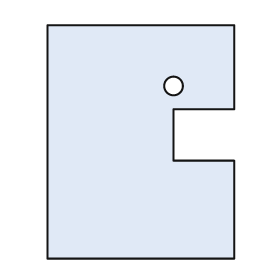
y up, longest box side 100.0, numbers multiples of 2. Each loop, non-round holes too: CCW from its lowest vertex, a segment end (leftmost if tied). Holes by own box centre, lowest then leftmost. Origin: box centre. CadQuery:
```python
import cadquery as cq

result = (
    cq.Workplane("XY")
    .moveTo(-40.0, -50.0)
    .lineTo(40.0, -50.0)
    .lineTo(40.0, -8.0)
    .lineTo(14.0, -8.0)
    .lineTo(14.0, 14.0)
    .lineTo(40.0, 14.0)
    .lineTo(40.0, 50.0)
    .lineTo(-40.0, 50.0)
    .close()
    .moveTo(14.0, 24.0)
    .circle(4.0)
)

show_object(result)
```